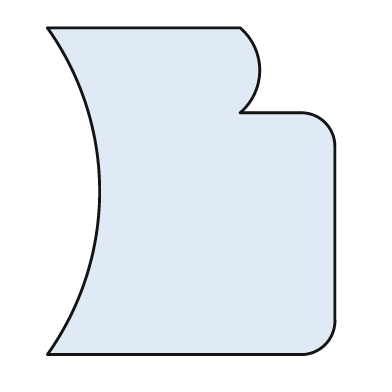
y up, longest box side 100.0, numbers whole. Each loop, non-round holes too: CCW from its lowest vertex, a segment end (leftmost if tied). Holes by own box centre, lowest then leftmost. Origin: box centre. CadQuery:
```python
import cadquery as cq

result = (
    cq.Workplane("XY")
    .moveTo(-44.0, -50.0)
    .lineTo(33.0, -50.0)
    .threePointArc((41.0, -47.0), (44.0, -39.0))
    .lineTo(44.0, 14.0)
    .threePointArc((41.0, 21.0), (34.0, 24.0))
    .lineTo(15.0, 24.0)
    .threePointArc((21.0, 37.0), (15.0, 50.0))
    .lineTo(-44.0, 50.0)
    .threePointArc((-28.0, 0.0), (-44.0, -50.0))
    .close()
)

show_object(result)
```